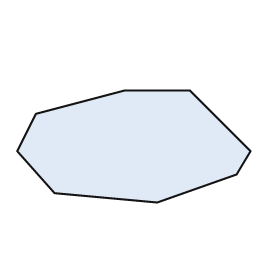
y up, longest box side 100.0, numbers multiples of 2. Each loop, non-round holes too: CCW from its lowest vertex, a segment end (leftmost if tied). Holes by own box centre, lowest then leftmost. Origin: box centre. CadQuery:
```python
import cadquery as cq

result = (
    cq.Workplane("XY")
    .moveTo(10.0, -24.0)
    .lineTo(44.0, -12.0)
    .lineTo(50.0, -2.0)
    .lineTo(24.0, 24.0)
    .lineTo(-4.0, 24.0)
    .lineTo(-42.0, 14.0)
    .lineTo(-50.0, -2.0)
    .lineTo(-34.0, -20.0)
    .close()
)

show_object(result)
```